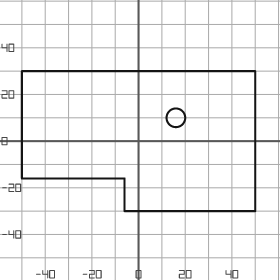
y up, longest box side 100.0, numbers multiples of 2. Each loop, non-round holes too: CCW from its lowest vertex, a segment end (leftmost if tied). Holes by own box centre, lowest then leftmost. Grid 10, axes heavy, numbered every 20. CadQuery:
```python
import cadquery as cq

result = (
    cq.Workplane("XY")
    .moveTo(-6.0, -30.0)
    .lineTo(50.0, -30.0)
    .lineTo(50.0, 30.0)
    .lineTo(-50.0, 30.0)
    .lineTo(-50.0, -16.0)
    .lineTo(-6.0, -16.0)
    .close()
    .moveTo(16.0, 10.0)
    .circle(4.0)
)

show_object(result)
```